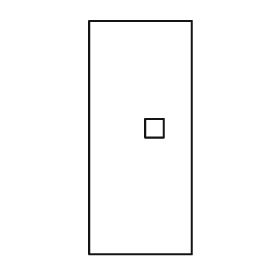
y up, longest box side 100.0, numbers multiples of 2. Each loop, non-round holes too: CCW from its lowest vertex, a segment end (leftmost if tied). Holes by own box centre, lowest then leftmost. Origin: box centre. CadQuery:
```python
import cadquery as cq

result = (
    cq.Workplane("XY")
    .moveTo(-22.0, -50.0)
    .lineTo(22.0, -50.0)
    .lineTo(22.0, 50.0)
    .lineTo(-22.0, 50.0)
    .close()
    .moveTo(2.0, 0.0)
    .lineTo(10.0, 0.0)
    .lineTo(10.0, 8.0)
    .lineTo(2.0, 8.0)
    .close()
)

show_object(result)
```